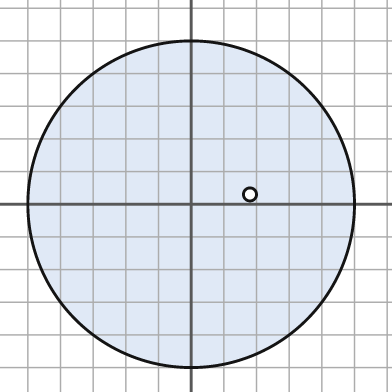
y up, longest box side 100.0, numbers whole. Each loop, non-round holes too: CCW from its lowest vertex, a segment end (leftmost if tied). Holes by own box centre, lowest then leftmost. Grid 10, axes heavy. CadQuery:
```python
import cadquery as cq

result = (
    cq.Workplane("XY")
    .moveTo(0.0, 0.0)
    .circle(50.0)
    .moveTo(18.0, 3.0)
    .circle(2.0)
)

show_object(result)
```